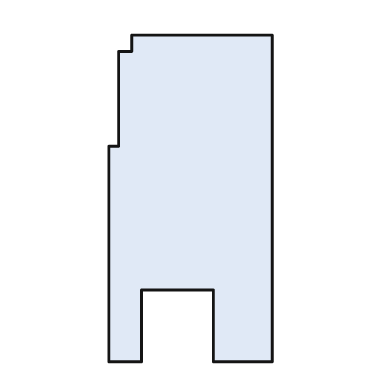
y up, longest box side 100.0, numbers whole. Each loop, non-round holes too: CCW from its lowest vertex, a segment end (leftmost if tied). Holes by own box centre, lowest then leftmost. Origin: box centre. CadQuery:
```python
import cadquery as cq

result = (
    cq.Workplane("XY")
    .moveTo(-25.0, -50.0)
    .lineTo(-15.0, -50.0)
    .lineTo(-15.0, -28.0)
    .lineTo(7.0, -28.0)
    .lineTo(7.0, -50.0)
    .lineTo(25.0, -50.0)
    .lineTo(25.0, 50.0)
    .lineTo(-18.0, 50.0)
    .lineTo(-18.0, 45.0)
    .lineTo(-22.0, 45.0)
    .lineTo(-22.0, 16.0)
    .lineTo(-25.0, 16.0)
    .close()
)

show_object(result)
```